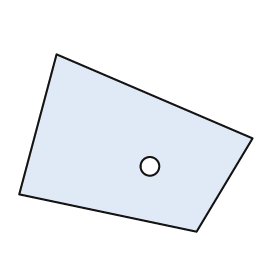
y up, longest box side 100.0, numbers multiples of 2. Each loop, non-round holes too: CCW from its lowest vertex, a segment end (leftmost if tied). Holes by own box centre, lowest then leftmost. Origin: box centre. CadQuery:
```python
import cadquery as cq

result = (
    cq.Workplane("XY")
    .moveTo(26.0, -38.0)
    .lineTo(50.0, 2.0)
    .lineTo(-34.0, 38.0)
    .lineTo(-50.0, -22.0)
    .close()
    .moveTo(6.0, -10.0)
    .circle(4.0)
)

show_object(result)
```